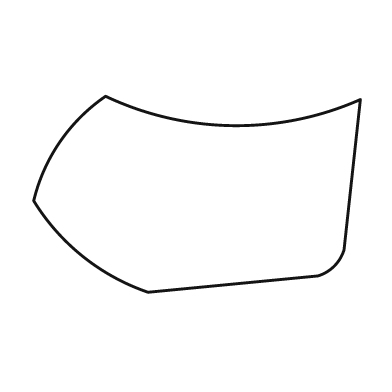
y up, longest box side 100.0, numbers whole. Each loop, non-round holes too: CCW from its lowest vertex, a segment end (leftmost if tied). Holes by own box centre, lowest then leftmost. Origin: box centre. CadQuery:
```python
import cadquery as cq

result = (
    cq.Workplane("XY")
    .moveTo(-15.0, -30.0)
    .lineTo(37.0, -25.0)
    .threePointArc((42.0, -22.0), (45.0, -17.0))
    .lineTo(50.0, 29.0)
    .threePointArc((11.0, 21.0), (-28.0, 30.0))
    .threePointArc((-42.0, 16.0), (-50.0, -2.0))
    .threePointArc((-35.0, -19.0), (-15.0, -30.0))
    .close()
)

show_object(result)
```